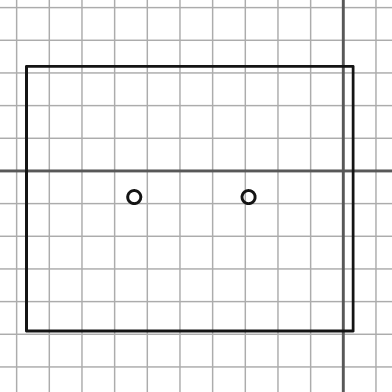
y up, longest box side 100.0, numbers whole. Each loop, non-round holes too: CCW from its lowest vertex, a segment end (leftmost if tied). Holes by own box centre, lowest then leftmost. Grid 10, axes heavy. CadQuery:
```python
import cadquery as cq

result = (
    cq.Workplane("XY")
    .moveTo(-97.0, -49.0)
    .lineTo(3.0, -49.0)
    .lineTo(3.0, 32.0)
    .lineTo(-97.0, 32.0)
    .close()
    .moveTo(-64.0, -8.0)
    .circle(2.0)
    .moveTo(-29.0, -8.0)
    .circle(2.0)
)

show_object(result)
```